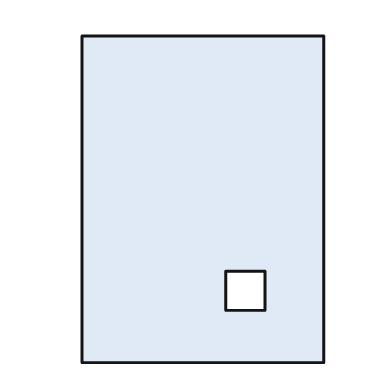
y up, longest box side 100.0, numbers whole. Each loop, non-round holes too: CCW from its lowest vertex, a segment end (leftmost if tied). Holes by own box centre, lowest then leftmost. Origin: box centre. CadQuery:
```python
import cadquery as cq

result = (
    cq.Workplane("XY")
    .moveTo(-37.0, -50.0)
    .lineTo(37.0, -50.0)
    .lineTo(37.0, 50.0)
    .lineTo(-37.0, 50.0)
    .close()
    .moveTo(7.0, -34.0)
    .lineTo(19.0, -34.0)
    .lineTo(19.0, -22.0)
    .lineTo(7.0, -22.0)
    .close()
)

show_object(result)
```